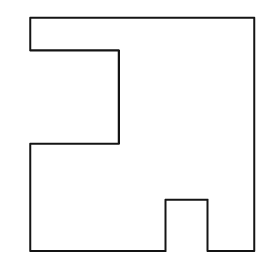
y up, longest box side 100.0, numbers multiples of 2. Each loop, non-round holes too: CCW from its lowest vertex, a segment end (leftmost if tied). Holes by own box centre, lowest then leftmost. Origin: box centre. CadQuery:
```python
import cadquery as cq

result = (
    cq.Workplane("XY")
    .moveTo(-48.0, -50.0)
    .lineTo(10.0, -50.0)
    .lineTo(10.0, -28.0)
    .lineTo(28.0, -28.0)
    .lineTo(28.0, -50.0)
    .lineTo(48.0, -50.0)
    .lineTo(48.0, 50.0)
    .lineTo(-48.0, 50.0)
    .lineTo(-48.0, 36.0)
    .lineTo(-10.0, 36.0)
    .lineTo(-10.0, -4.0)
    .lineTo(-48.0, -4.0)
    .close()
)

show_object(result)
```